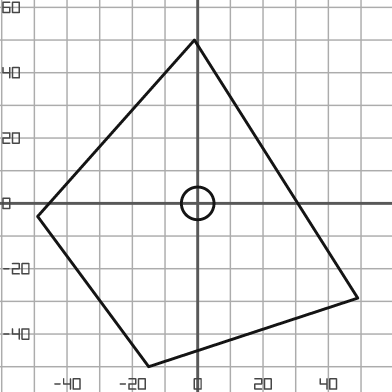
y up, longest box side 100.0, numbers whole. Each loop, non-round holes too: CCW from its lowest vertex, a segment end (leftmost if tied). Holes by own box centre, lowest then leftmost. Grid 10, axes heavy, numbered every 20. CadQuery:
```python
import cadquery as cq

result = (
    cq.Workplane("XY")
    .moveTo(-15.0, -50.0)
    .lineTo(49.0, -29.0)
    .lineTo(-1.0, 50.0)
    .lineTo(-49.0, -4.0)
    .close()
    .moveTo(0.0, 0.0)
    .circle(5.0)
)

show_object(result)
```